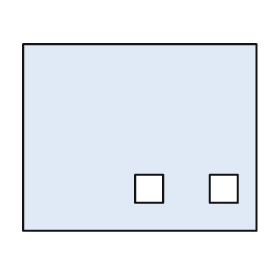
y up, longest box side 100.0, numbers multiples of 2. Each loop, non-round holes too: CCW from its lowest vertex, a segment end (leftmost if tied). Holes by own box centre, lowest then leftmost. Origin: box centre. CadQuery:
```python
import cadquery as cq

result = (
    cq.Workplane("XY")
    .moveTo(-50.0, -40.0)
    .lineTo(50.0, -40.0)
    .lineTo(50.0, 40.0)
    .lineTo(-50.0, 40.0)
    .close()
    .moveTo(-2.0, -28.0)
    .lineTo(10.0, -28.0)
    .lineTo(10.0, -16.0)
    .lineTo(-2.0, -16.0)
    .close()
    .moveTo(30.0, -28.0)
    .lineTo(42.0, -28.0)
    .lineTo(42.0, -16.0)
    .lineTo(30.0, -16.0)
    .close()
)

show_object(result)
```